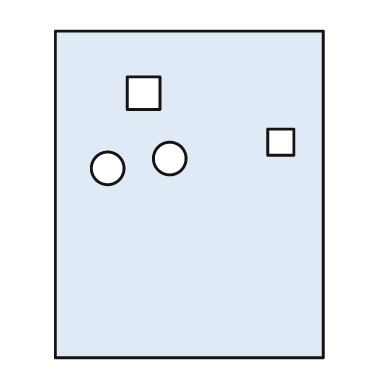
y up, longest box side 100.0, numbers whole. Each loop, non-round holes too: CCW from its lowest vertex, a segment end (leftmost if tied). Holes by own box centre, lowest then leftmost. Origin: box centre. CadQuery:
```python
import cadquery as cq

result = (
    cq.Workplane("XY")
    .moveTo(-41.0, -50.0)
    .lineTo(41.0, -50.0)
    .lineTo(41.0, 50.0)
    .lineTo(-41.0, 50.0)
    .close()
    .moveTo(-25.0, 8.0)
    .circle(5.0)
    .moveTo(-6.0, 11.0)
    .circle(5.0)
    .moveTo(24.0, 12.0)
    .lineTo(32.0, 12.0)
    .lineTo(32.0, 20.0)
    .lineTo(24.0, 20.0)
    .close()
    .moveTo(-19.0, 26.0)
    .lineTo(-9.0, 26.0)
    .lineTo(-9.0, 36.0)
    .lineTo(-19.0, 36.0)
    .close()
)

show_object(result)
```